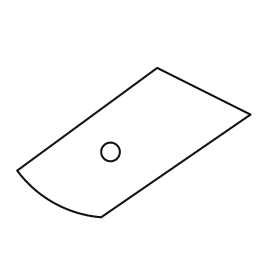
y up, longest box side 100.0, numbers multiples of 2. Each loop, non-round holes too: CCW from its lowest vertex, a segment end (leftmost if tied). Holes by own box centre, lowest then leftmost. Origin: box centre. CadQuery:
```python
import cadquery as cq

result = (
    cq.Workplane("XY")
    .moveTo(-14.0, -32.0)
    .lineTo(50.0, 12.0)
    .lineTo(10.0, 32.0)
    .lineTo(-50.0, -12.0)
    .threePointArc((-34.0, -26.0), (-14.0, -32.0))
    .close()
    .moveTo(-10.0, -4.0)
    .circle(4.0)
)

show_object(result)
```